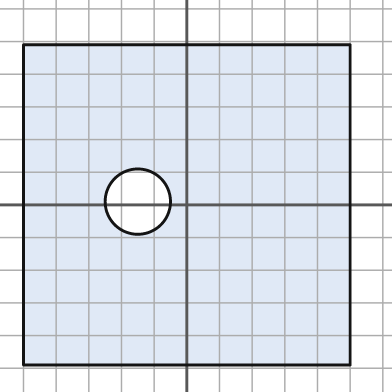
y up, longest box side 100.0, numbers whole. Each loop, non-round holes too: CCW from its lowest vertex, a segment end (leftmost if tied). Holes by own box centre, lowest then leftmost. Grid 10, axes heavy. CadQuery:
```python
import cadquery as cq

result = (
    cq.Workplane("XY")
    .moveTo(-50.0, -49.0)
    .lineTo(50.0, -49.0)
    .lineTo(50.0, 49.0)
    .lineTo(-50.0, 49.0)
    .close()
    .moveTo(-15.0, 1.0)
    .circle(10.0)
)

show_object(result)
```